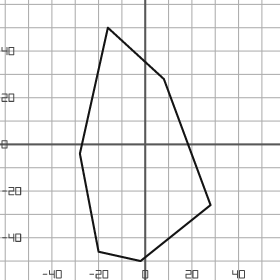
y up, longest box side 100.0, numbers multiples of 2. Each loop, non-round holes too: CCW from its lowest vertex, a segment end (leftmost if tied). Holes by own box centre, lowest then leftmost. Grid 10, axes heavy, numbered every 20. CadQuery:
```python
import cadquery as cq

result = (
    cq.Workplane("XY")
    .moveTo(-2.0, -50.0)
    .lineTo(28.0, -26.0)
    .lineTo(8.0, 28.0)
    .lineTo(-16.0, 50.0)
    .lineTo(-28.0, -4.0)
    .lineTo(-20.0, -46.0)
    .close()
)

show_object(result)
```